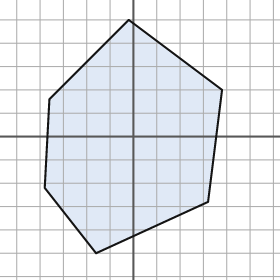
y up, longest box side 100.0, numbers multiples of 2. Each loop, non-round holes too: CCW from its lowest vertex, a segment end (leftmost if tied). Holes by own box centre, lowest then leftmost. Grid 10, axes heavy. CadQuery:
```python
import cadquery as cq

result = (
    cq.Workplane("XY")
    .moveTo(-16.0, -50.0)
    .lineTo(32.0, -28.0)
    .lineTo(38.0, 20.0)
    .lineTo(-2.0, 50.0)
    .lineTo(-36.0, 16.0)
    .lineTo(-38.0, -22.0)
    .close()
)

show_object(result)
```